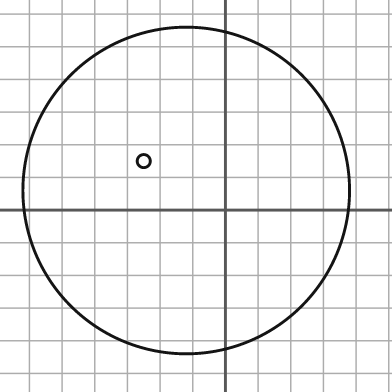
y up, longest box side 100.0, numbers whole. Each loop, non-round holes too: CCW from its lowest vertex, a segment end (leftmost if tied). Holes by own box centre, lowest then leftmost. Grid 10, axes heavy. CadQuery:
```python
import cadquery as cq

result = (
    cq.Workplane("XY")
    .moveTo(-12.0, 6.0)
    .circle(50.0)
    .moveTo(-25.0, 15.0)
    .circle(2.0)
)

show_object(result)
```